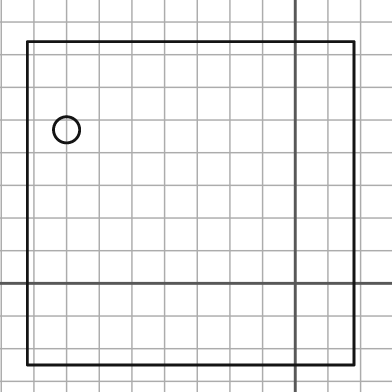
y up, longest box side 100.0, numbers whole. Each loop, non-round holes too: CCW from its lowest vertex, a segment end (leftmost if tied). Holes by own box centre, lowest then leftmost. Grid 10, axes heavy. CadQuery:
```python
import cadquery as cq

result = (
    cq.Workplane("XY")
    .moveTo(-82.0, -25.0)
    .lineTo(18.0, -25.0)
    .lineTo(18.0, 74.0)
    .lineTo(-82.0, 74.0)
    .close()
    .moveTo(-70.0, 47.0)
    .circle(4.0)
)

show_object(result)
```